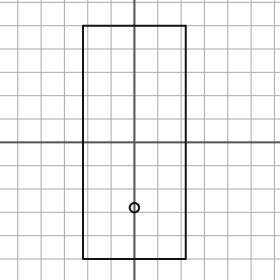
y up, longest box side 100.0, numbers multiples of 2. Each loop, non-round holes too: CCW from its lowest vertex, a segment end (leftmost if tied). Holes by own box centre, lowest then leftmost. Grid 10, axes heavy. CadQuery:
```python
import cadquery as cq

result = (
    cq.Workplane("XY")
    .moveTo(-22.0, -50.0)
    .lineTo(22.0, -50.0)
    .lineTo(22.0, 50.0)
    .lineTo(-22.0, 50.0)
    .close()
    .moveTo(0.0, -28.0)
    .circle(2.0)
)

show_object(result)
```